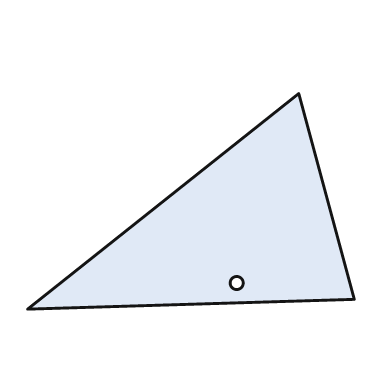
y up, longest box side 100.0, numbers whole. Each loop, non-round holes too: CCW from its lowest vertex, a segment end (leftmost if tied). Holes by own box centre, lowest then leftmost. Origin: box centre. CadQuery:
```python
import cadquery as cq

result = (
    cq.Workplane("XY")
    .moveTo(-50.0, -33.0)
    .lineTo(50.0, -30.0)
    .lineTo(33.0, 33.0)
    .close()
    .moveTo(14.0, -25.0)
    .circle(2.0)
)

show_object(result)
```